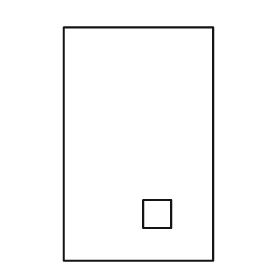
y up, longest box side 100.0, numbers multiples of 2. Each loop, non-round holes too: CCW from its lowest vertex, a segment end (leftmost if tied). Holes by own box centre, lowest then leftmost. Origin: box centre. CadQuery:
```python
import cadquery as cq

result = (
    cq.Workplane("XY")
    .moveTo(-32.0, -50.0)
    .lineTo(32.0, -50.0)
    .lineTo(32.0, 50.0)
    .lineTo(-32.0, 50.0)
    .close()
    .moveTo(2.0, -36.0)
    .lineTo(14.0, -36.0)
    .lineTo(14.0, -24.0)
    .lineTo(2.0, -24.0)
    .close()
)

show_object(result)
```